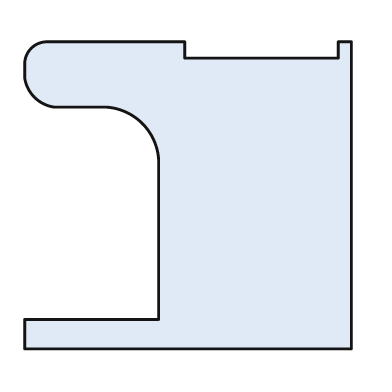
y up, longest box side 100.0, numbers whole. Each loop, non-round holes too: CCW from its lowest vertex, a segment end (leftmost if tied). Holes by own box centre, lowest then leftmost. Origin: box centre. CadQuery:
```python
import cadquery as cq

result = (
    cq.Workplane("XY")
    .moveTo(-50.0, -47.0)
    .lineTo(50.0, -47.0)
    .lineTo(50.0, 47.0)
    .lineTo(46.0, 47.0)
    .lineTo(46.0, 42.0)
    .lineTo(-1.0, 42.0)
    .lineTo(-1.0, 47.0)
    .lineTo(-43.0, 47.0)
    .threePointArc((-48.0, 45.0), (-50.0, 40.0))
    .lineTo(-50.0, 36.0)
    .threePointArc((-47.0, 30.0), (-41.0, 27.0))
    .lineTo(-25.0, 27.0)
    .threePointArc((-14.0, 22.0), (-9.0, 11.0))
    .lineTo(-9.0, -38.0)
    .lineTo(-50.0, -38.0)
    .close()
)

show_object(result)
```